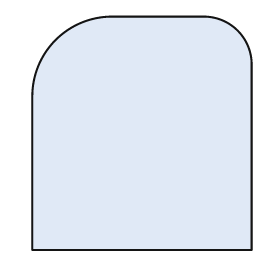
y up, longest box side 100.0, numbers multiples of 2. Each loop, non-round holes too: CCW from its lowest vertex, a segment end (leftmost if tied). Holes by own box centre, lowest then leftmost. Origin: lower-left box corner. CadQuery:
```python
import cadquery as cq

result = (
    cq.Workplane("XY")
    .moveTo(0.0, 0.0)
    .lineTo(94.0, 0.0)
    .lineTo(94.0, 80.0)
    .threePointArc((88.0, 94.0), (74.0, 100.0))
    .lineTo(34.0, 100.0)
    .threePointArc((10.0, 90.0), (0.0, 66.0))
    .close()
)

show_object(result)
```